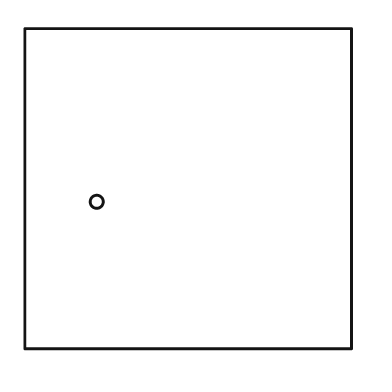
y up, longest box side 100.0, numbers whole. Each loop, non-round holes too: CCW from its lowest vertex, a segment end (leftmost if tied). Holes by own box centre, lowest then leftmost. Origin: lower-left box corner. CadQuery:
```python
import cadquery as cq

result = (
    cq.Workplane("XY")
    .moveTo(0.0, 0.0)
    .lineTo(100.0, 0.0)
    .lineTo(100.0, 98.0)
    .lineTo(0.0, 98.0)
    .close()
    .moveTo(22.0, 45.0)
    .circle(2.0)
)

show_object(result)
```